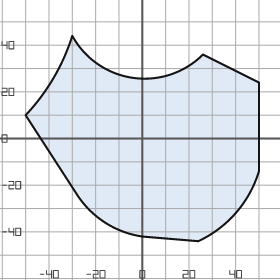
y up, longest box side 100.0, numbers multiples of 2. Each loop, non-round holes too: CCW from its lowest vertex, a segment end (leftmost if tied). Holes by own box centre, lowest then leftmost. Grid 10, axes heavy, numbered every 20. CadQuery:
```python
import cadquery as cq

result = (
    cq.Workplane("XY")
    .moveTo(24.0, -44.0)
    .threePointArc((40.0, -32.0), (50.0, -14.0))
    .lineTo(50.0, 24.0)
    .lineTo(26.0, 36.0)
    .threePointArc((-4.0, 26.0), (-30.0, 44.0))
    .threePointArc((-38.0, 26.0), (-50.0, 10.0))
    .lineTo(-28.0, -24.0)
    .threePointArc((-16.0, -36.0), (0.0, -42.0))
    .close()
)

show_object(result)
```